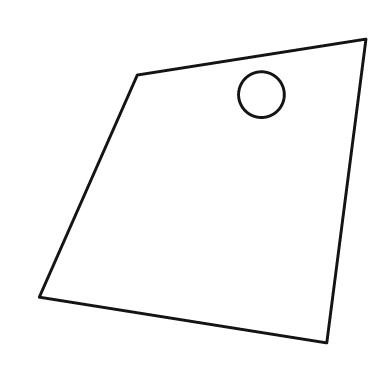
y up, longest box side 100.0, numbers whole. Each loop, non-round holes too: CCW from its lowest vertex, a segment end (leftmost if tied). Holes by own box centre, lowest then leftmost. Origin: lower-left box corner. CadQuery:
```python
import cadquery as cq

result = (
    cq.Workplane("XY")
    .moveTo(88.0, 0.0)
    .lineTo(100.0, 93.0)
    .lineTo(30.0, 82.0)
    .lineTo(0.0, 14.0)
    .close()
    .moveTo(68.0, 76.0)
    .circle(7.0)
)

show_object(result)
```